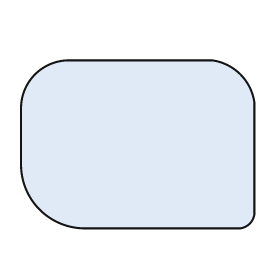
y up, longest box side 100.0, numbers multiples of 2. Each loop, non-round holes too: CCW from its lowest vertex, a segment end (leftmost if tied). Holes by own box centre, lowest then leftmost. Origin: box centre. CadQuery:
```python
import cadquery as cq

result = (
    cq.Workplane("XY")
    .moveTo(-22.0, -36.0)
    .lineTo(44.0, -36.0)
    .threePointArc((48.0, -34.0), (50.0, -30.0))
    .lineTo(50.0, 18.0)
    .threePointArc((44.0, 30.0), (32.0, 36.0))
    .lineTo(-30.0, 36.0)
    .threePointArc((-44.0, 30.0), (-50.0, 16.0))
    .lineTo(-50.0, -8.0)
    .threePointArc((-42.0, -28.0), (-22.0, -36.0))
    .close()
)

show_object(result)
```